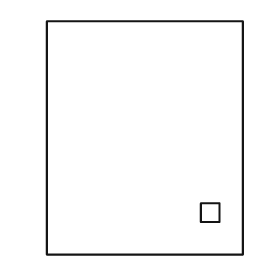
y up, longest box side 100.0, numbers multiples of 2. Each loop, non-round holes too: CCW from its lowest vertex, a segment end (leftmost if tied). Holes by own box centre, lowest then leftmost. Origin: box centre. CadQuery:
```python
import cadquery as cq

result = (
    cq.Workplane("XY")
    .moveTo(-42.0, -50.0)
    .lineTo(42.0, -50.0)
    .lineTo(42.0, 50.0)
    .lineTo(-42.0, 50.0)
    .close()
    .moveTo(24.0, -36.0)
    .lineTo(32.0, -36.0)
    .lineTo(32.0, -28.0)
    .lineTo(24.0, -28.0)
    .close()
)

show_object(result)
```